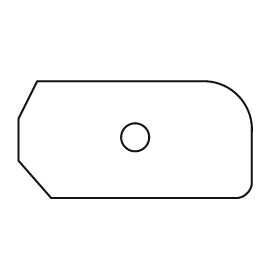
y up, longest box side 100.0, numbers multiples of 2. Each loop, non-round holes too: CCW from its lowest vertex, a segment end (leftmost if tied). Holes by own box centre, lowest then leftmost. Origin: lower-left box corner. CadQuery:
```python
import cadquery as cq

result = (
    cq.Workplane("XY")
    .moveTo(14.0, 0.0)
    .lineTo(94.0, 0.0)
    .threePointArc((98.0, 2.0), (100.0, 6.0))
    .lineTo(100.0, 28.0)
    .threePointArc((94.0, 44.0), (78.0, 50.0))
    .lineTo(8.0, 50.0)
    .lineTo(0.0, 34.0)
    .lineTo(0.0, 16.0)
    .close()
    .moveTo(50.0, 26.0)
    .circle(6.0)
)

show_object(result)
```